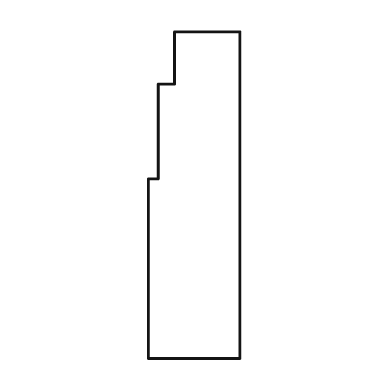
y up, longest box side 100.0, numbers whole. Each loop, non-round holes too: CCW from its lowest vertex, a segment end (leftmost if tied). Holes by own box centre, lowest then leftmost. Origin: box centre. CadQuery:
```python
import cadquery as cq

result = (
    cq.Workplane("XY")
    .moveTo(-14.0, -50.0)
    .lineTo(14.0, -50.0)
    .lineTo(14.0, 50.0)
    .lineTo(-6.0, 50.0)
    .lineTo(-6.0, 34.0)
    .lineTo(-11.0, 34.0)
    .lineTo(-11.0, 5.0)
    .lineTo(-14.0, 5.0)
    .close()
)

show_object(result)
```